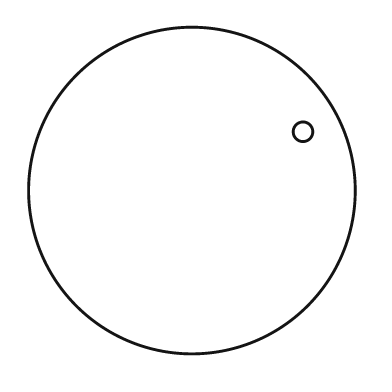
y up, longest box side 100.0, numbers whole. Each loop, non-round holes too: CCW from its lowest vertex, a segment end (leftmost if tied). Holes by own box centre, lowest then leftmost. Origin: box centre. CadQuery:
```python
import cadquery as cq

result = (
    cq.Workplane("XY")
    .moveTo(0.0, 0.0)
    .circle(50.0)
    .moveTo(34.0, 18.0)
    .circle(3.0)
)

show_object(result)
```